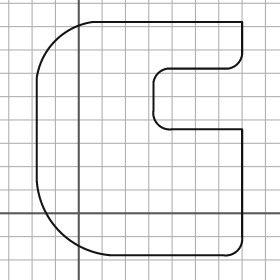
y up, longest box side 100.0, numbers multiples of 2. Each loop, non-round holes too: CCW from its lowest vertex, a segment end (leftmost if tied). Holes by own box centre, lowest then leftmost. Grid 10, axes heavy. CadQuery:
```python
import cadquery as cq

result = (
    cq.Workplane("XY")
    .moveTo(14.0, -18.0)
    .lineTo(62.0, -18.0)
    .threePointArc((68.0, -16.0), (70.0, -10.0))
    .lineTo(70.0, 36.0)
    .lineTo(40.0, 36.0)
    .threePointArc((34.0, 38.0), (32.0, 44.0))
    .lineTo(32.0, 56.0)
    .threePointArc((34.0, 60.0), (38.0, 62.0))
    .lineTo(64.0, 62.0)
    .threePointArc((68.0, 64.0), (70.0, 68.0))
    .lineTo(70.0, 82.0)
    .lineTo(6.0, 82.0)
    .threePointArc((-10.0, 74.0), (-18.0, 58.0))
    .lineTo(-18.0, 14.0)
    .threePointArc((-8.0, -8.0), (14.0, -18.0))
    .close()
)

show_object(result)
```